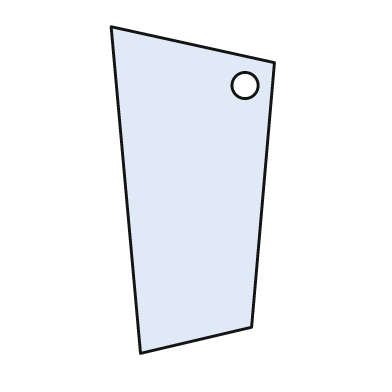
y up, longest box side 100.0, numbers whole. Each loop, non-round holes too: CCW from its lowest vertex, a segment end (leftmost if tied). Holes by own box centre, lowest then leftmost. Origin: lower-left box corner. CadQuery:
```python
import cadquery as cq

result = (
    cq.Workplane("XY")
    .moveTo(9.0, 0.0)
    .lineTo(43.0, 8.0)
    .lineTo(50.0, 89.0)
    .lineTo(0.0, 100.0)
    .close()
    .moveTo(41.0, 82.0)
    .circle(4.0)
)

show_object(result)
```